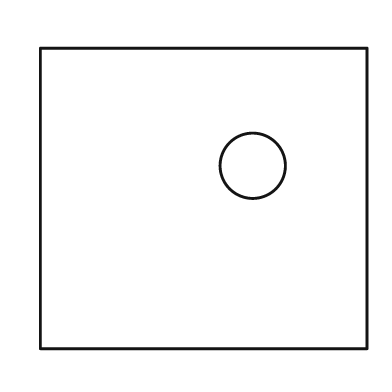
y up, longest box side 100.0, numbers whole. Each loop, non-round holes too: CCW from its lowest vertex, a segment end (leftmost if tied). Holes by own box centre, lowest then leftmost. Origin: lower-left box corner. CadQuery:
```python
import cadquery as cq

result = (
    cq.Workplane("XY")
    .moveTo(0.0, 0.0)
    .lineTo(100.0, 0.0)
    .lineTo(100.0, 92.0)
    .lineTo(0.0, 92.0)
    .close()
    .moveTo(65.0, 56.0)
    .circle(10.0)
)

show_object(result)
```